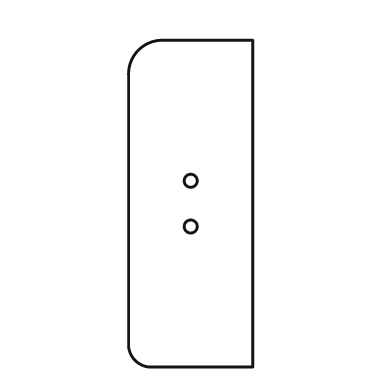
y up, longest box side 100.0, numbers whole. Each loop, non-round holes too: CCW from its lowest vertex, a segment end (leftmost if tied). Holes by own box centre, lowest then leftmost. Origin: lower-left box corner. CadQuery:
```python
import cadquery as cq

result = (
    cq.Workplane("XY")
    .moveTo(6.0, 0.0)
    .lineTo(38.0, 0.0)
    .lineTo(38.0, 100.0)
    .lineTo(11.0, 100.0)
    .threePointArc((3.0, 97.0), (0.0, 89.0))
    .lineTo(0.0, 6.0)
    .threePointArc((2.0, 2.0), (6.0, 0.0))
    .close()
    .moveTo(19.0, 43.0)
    .circle(2.0)
    .moveTo(19.0, 57.0)
    .circle(2.0)
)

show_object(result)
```